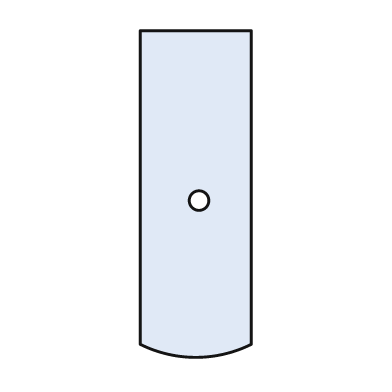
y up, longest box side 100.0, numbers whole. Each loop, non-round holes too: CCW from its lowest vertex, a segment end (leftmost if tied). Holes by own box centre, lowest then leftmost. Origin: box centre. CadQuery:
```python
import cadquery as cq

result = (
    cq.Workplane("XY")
    .moveTo(-17.0, -46.0)
    .threePointArc((0.0, -50.0), (17.0, -46.0))
    .lineTo(17.0, 50.0)
    .lineTo(-17.0, 50.0)
    .close()
    .moveTo(1.0, -2.0)
    .circle(3.0)
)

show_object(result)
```